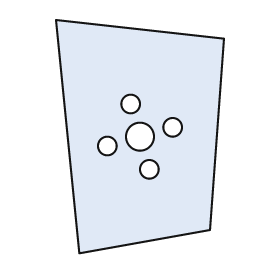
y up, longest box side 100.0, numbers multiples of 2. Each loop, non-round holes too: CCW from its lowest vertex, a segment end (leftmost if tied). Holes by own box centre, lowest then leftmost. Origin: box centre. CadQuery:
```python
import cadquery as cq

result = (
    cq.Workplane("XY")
    .moveTo(-26.0, -50.0)
    .lineTo(30.0, -40.0)
    .lineTo(36.0, 42.0)
    .lineTo(-36.0, 50.0)
    .close()
    .moveTo(4.0, -14.0)
    .circle(4.0)
    .moveTo(-14.0, -4.0)
    .circle(4.0)
    .moveTo(0.0, 0.0)
    .circle(6.0)
    .moveTo(14.0, 4.0)
    .circle(4.0)
    .moveTo(-4.0, 14.0)
    .circle(4.0)
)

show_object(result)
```